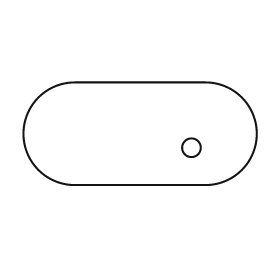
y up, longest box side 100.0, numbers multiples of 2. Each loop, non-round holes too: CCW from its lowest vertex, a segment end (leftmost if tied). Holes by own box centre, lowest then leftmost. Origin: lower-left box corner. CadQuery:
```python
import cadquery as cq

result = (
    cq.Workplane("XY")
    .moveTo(22.0, 0.0)
    .lineTo(78.0, 0.0)
    .threePointArc((100.0, 22.0), (78.0, 44.0))
    .lineTo(22.0, 44.0)
    .threePointArc((0.0, 22.0), (22.0, 0.0))
    .close()
    .moveTo(72.0, 16.0)
    .circle(4.0)
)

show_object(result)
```